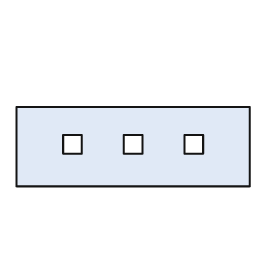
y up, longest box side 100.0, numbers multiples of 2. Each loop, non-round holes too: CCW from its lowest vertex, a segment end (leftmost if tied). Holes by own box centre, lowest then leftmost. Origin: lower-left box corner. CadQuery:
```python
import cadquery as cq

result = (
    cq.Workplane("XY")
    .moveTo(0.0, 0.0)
    .lineTo(100.0, 0.0)
    .lineTo(100.0, 34.0)
    .lineTo(0.0, 34.0)
    .close()
    .moveTo(20.0, 14.0)
    .lineTo(28.0, 14.0)
    .lineTo(28.0, 22.0)
    .lineTo(20.0, 22.0)
    .close()
    .moveTo(46.0, 14.0)
    .lineTo(54.0, 14.0)
    .lineTo(54.0, 22.0)
    .lineTo(46.0, 22.0)
    .close()
    .moveTo(72.0, 14.0)
    .lineTo(80.0, 14.0)
    .lineTo(80.0, 22.0)
    .lineTo(72.0, 22.0)
    .close()
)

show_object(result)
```